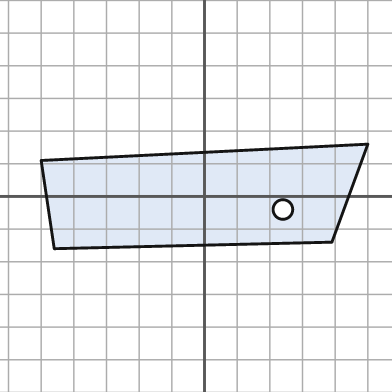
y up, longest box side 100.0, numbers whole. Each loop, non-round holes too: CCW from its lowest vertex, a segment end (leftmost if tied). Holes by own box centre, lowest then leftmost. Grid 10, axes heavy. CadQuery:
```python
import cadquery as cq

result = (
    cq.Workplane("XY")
    .moveTo(-46.0, -16.0)
    .lineTo(39.0, -14.0)
    .lineTo(50.0, 16.0)
    .lineTo(-50.0, 11.0)
    .close()
    .moveTo(24.0, -4.0)
    .circle(3.0)
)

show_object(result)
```